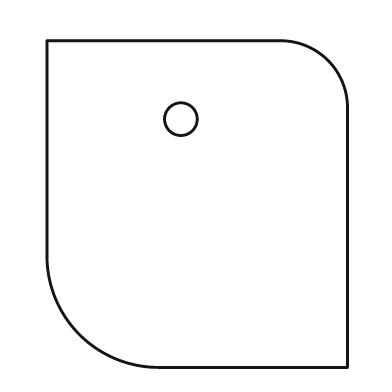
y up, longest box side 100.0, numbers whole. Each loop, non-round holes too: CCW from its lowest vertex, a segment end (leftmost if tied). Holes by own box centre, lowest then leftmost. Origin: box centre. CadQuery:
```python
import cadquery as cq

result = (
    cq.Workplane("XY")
    .moveTo(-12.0, -50.0)
    .lineTo(46.0, -50.0)
    .lineTo(46.0, 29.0)
    .threePointArc((40.0, 44.0), (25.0, 50.0))
    .lineTo(-46.0, 50.0)
    .lineTo(-46.0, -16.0)
    .threePointArc((-36.0, -40.0), (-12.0, -50.0))
    .close()
    .moveTo(-5.0, 26.0)
    .circle(5.0)
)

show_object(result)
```